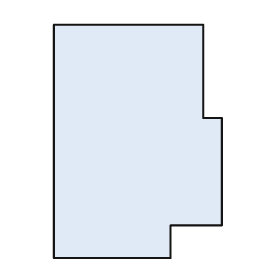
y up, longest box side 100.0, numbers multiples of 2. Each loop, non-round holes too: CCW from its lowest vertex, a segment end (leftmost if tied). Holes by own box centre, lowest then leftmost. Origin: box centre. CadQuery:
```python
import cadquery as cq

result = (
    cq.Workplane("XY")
    .moveTo(-36.0, -50.0)
    .lineTo(14.0, -50.0)
    .lineTo(14.0, -36.0)
    .lineTo(36.0, -36.0)
    .lineTo(36.0, 10.0)
    .lineTo(28.0, 10.0)
    .lineTo(28.0, 50.0)
    .lineTo(-36.0, 50.0)
    .close()
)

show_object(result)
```